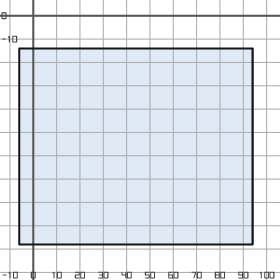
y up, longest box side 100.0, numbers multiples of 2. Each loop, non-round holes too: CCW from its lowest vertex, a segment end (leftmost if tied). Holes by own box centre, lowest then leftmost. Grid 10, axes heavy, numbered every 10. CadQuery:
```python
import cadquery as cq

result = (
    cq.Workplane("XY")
    .moveTo(-6.0, -98.0)
    .lineTo(94.0, -98.0)
    .lineTo(94.0, -14.0)
    .lineTo(-6.0, -14.0)
    .close()
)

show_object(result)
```